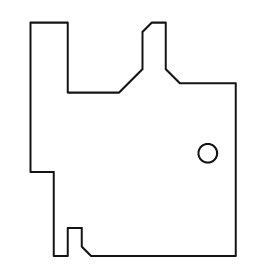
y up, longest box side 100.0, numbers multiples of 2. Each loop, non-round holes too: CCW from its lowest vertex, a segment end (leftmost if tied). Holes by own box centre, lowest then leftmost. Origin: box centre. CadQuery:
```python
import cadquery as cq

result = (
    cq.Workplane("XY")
    .moveTo(-34.0, -50.0)
    .lineTo(-28.0, -50.0)
    .lineTo(-28.0, -38.0)
    .lineTo(-22.0, -38.0)
    .lineTo(-22.0, -46.0)
    .lineTo(-18.0, -50.0)
    .lineTo(44.0, -50.0)
    .lineTo(44.0, 24.0)
    .lineTo(20.0, 24.0)
    .lineTo(14.0, 30.0)
    .lineTo(14.0, 50.0)
    .lineTo(8.0, 50.0)
    .lineTo(4.0, 46.0)
    .lineTo(4.0, 30.0)
    .lineTo(-6.0, 20.0)
    .lineTo(-28.0, 20.0)
    .lineTo(-28.0, 50.0)
    .lineTo(-44.0, 50.0)
    .lineTo(-44.0, -14.0)
    .lineTo(-34.0, -14.0)
    .close()
    .moveTo(32.0, -6.0)
    .circle(4.0)
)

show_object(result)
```